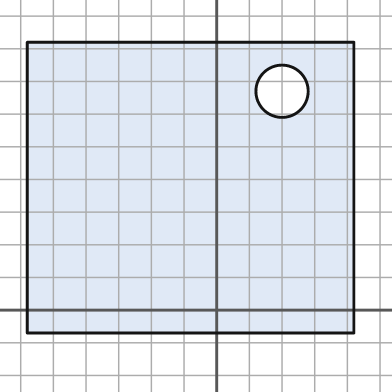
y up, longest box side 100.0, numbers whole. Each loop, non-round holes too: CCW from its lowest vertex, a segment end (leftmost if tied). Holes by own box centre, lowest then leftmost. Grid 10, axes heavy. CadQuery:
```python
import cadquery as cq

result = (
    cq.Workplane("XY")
    .moveTo(-58.0, -7.0)
    .lineTo(42.0, -7.0)
    .lineTo(42.0, 82.0)
    .lineTo(-58.0, 82.0)
    .close()
    .moveTo(20.0, 67.0)
    .circle(8.0)
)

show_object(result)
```